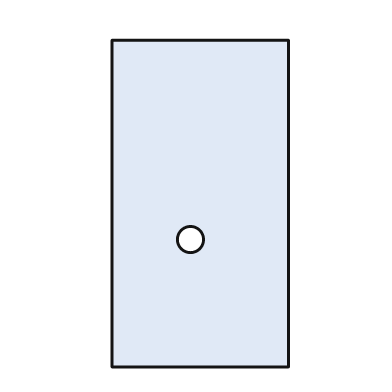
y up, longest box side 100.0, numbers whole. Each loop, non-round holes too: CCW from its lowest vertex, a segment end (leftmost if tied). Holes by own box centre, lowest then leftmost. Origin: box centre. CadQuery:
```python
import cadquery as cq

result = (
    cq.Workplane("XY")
    .moveTo(-27.0, -50.0)
    .lineTo(27.0, -50.0)
    .lineTo(27.0, 50.0)
    .lineTo(-27.0, 50.0)
    .close()
    .moveTo(-3.0, -11.0)
    .circle(4.0)
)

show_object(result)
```